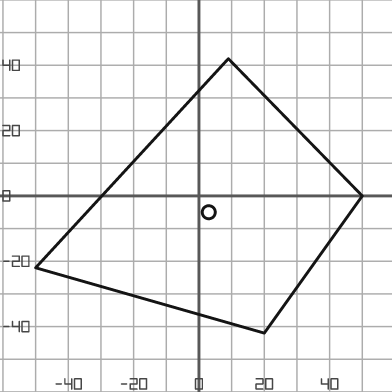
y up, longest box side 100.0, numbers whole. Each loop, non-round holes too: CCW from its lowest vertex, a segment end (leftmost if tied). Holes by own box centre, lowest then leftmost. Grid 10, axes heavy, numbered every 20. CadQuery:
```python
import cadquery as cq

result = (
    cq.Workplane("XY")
    .moveTo(20.0, -42.0)
    .lineTo(50.0, 0.0)
    .lineTo(9.0, 42.0)
    .lineTo(-50.0, -22.0)
    .close()
    .moveTo(3.0, -5.0)
    .circle(2.0)
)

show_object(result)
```